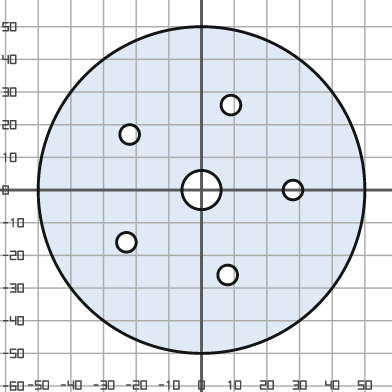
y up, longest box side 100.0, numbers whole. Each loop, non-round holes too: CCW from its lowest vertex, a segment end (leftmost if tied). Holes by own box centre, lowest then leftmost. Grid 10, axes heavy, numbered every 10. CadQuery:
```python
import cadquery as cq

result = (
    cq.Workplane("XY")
    .moveTo(0.0, 0.0)
    .circle(50.0)
    .moveTo(8.0, -26.0)
    .circle(3.0)
    .moveTo(-23.0, -16.0)
    .circle(3.0)
    .moveTo(0.0, 0.0)
    .circle(6.0)
    .moveTo(28.0, 0.0)
    .circle(3.0)
    .moveTo(-22.0, 17.0)
    .circle(3.0)
    .moveTo(9.0, 26.0)
    .circle(3.0)
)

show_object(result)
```